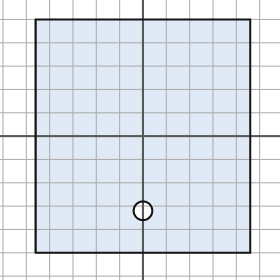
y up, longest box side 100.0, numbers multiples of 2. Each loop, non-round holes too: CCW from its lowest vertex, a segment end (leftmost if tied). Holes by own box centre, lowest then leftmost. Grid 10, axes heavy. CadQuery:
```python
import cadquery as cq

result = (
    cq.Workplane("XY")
    .moveTo(-46.0, -50.0)
    .lineTo(46.0, -50.0)
    .lineTo(46.0, 50.0)
    .lineTo(-46.0, 50.0)
    .close()
    .moveTo(0.0, -32.0)
    .circle(4.0)
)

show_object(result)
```